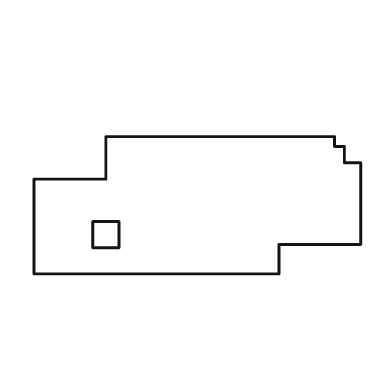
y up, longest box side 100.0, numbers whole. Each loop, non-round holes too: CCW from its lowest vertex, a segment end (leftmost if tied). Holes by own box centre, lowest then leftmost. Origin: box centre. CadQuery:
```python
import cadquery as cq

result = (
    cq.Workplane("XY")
    .moveTo(-50.0, -21.0)
    .lineTo(25.0, -21.0)
    .lineTo(25.0, -12.0)
    .lineTo(50.0, -12.0)
    .lineTo(50.0, 13.0)
    .lineTo(45.0, 13.0)
    .lineTo(45.0, 18.0)
    .lineTo(42.0, 18.0)
    .lineTo(42.0, 21.0)
    .lineTo(-28.0, 21.0)
    .lineTo(-28.0, 8.0)
    .lineTo(-50.0, 8.0)
    .close()
    .moveTo(-32.0, -13.0)
    .lineTo(-24.0, -13.0)
    .lineTo(-24.0, -5.0)
    .lineTo(-32.0, -5.0)
    .close()
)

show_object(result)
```